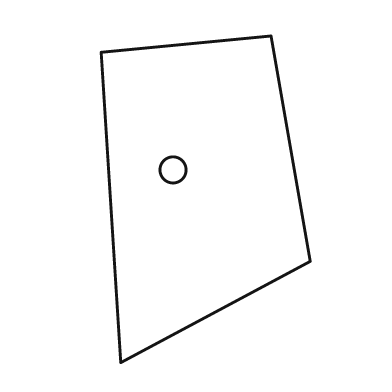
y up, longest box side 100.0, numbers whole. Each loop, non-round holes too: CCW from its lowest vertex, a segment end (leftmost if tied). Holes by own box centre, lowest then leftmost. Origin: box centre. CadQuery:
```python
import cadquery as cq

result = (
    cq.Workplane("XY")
    .moveTo(-26.0, -50.0)
    .lineTo(32.0, -19.0)
    .lineTo(20.0, 50.0)
    .lineTo(-32.0, 45.0)
    .close()
    .moveTo(-10.0, 9.0)
    .circle(4.0)
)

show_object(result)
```